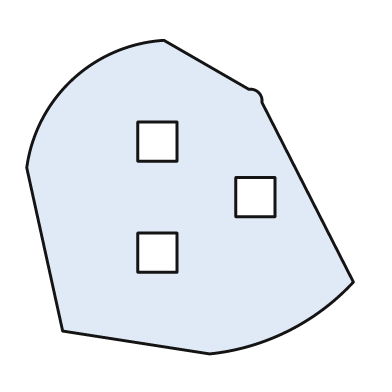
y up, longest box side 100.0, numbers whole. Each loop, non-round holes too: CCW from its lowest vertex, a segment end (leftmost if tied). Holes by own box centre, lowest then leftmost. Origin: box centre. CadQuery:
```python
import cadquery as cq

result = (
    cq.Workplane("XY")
    .moveTo(6.0, -48.0)
    .threePointArc((30.0, -41.0), (50.0, -26.0))
    .lineTo(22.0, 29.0)
    .threePointArc((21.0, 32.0), (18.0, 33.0))
    .lineTo(-8.0, 48.0)
    .threePointArc((-36.0, 36.0), (-50.0, 9.0))
    .lineTo(-39.0, -41.0)
    .close()
    .moveTo(-16.0, -23.0)
    .lineTo(-4.0, -23.0)
    .lineTo(-4.0, -11.0)
    .lineTo(-16.0, -11.0)
    .close()
    .moveTo(14.0, -6.0)
    .lineTo(26.0, -6.0)
    .lineTo(26.0, 6.0)
    .lineTo(14.0, 6.0)
    .close()
    .moveTo(-16.0, 11.0)
    .lineTo(-4.0, 11.0)
    .lineTo(-4.0, 23.0)
    .lineTo(-16.0, 23.0)
    .close()
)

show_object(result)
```